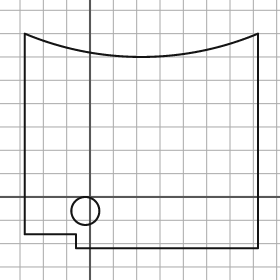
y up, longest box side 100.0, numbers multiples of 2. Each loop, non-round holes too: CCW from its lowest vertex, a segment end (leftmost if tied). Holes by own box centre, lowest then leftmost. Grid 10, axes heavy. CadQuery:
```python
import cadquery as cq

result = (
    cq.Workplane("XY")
    .moveTo(-6.0, -22.0)
    .lineTo(72.0, -22.0)
    .lineTo(72.0, 70.0)
    .threePointArc((22.0, 60.0), (-28.0, 70.0))
    .lineTo(-28.0, -16.0)
    .lineTo(-6.0, -16.0)
    .close()
    .moveTo(-2.0, -6.0)
    .circle(6.0)
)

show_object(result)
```